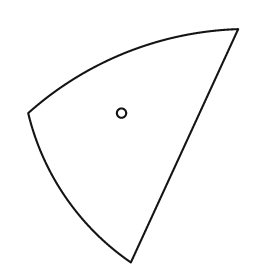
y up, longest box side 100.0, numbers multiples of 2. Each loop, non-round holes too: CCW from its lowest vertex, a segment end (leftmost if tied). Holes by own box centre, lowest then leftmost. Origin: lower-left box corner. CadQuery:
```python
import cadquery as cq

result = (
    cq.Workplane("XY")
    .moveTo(44.0, 0.0)
    .lineTo(90.0, 100.0)
    .threePointArc((42.0, 90.0), (0.0, 64.0))
    .threePointArc((16.0, 28.0), (44.0, 0.0))
    .close()
    .moveTo(40.0, 64.0)
    .circle(2.0)
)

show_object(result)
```